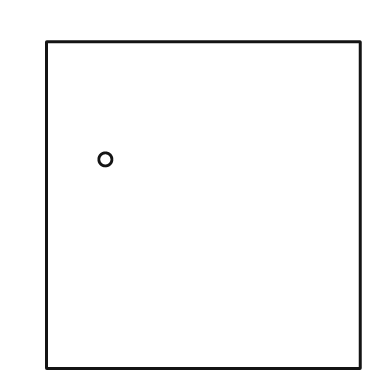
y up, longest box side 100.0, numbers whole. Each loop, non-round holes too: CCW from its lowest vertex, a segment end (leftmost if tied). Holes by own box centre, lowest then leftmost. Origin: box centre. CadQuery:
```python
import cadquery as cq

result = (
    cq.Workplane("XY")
    .moveTo(-48.0, -50.0)
    .lineTo(48.0, -50.0)
    .lineTo(48.0, 50.0)
    .lineTo(-48.0, 50.0)
    .close()
    .moveTo(-30.0, 14.0)
    .circle(2.0)
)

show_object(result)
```